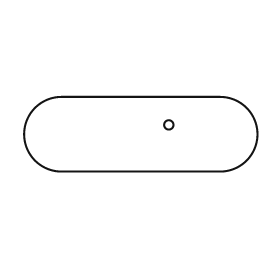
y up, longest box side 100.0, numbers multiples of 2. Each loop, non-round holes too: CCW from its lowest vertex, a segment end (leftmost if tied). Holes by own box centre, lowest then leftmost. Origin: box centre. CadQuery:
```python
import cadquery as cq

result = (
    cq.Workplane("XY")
    .moveTo(-34.0, -16.0)
    .lineTo(34.0, -16.0)
    .threePointArc((50.0, 0.0), (34.0, 16.0))
    .lineTo(-34.0, 16.0)
    .threePointArc((-50.0, 0.0), (-34.0, -16.0))
    .close()
    .moveTo(12.0, 4.0)
    .circle(2.0)
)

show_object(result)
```